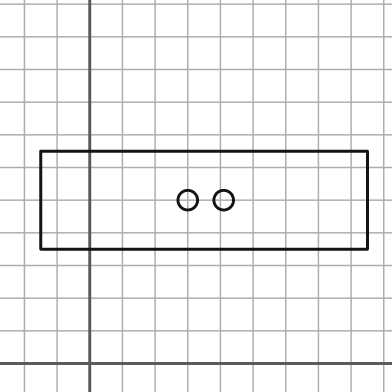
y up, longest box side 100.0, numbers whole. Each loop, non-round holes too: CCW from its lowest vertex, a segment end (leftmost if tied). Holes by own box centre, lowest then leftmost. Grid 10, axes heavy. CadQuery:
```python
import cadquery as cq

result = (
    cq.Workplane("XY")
    .moveTo(-15.0, 35.0)
    .lineTo(85.0, 35.0)
    .lineTo(85.0, 65.0)
    .lineTo(-15.0, 65.0)
    .close()
    .moveTo(30.0, 50.0)
    .circle(3.0)
    .moveTo(41.0, 50.0)
    .circle(3.0)
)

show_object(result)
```